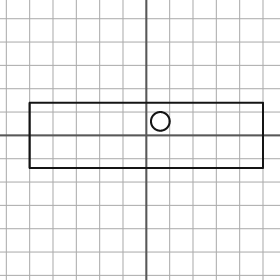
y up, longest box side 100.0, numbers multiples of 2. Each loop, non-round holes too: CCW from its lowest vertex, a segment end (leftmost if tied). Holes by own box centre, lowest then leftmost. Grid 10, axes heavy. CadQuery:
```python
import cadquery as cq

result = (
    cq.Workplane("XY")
    .moveTo(-50.0, -14.0)
    .lineTo(50.0, -14.0)
    .lineTo(50.0, 14.0)
    .lineTo(-50.0, 14.0)
    .close()
    .moveTo(6.0, 6.0)
    .circle(4.0)
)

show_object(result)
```